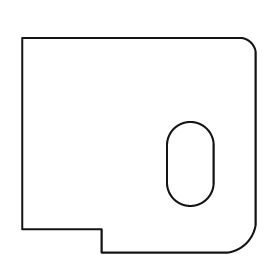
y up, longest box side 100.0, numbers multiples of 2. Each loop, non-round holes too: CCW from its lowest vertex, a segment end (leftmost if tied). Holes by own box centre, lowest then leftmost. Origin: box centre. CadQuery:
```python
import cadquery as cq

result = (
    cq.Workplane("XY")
    .moveTo(-16.0, -46.0)
    .lineTo(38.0, -46.0)
    .threePointArc((46.0, -42.0), (50.0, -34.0))
    .lineTo(50.0, 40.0)
    .threePointArc((48.0, 44.0), (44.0, 46.0))
    .lineTo(-50.0, 46.0)
    .lineTo(-50.0, -36.0)
    .lineTo(-16.0, -36.0)
    .close()
    .moveTo(12.0, -16.0)
    .threePointArc((22.0, -26.0), (32.0, -16.0))
    .lineTo(32.0, 0.0)
    .threePointArc((22.0, 10.0), (12.0, 0.0))
    .close()
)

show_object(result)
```